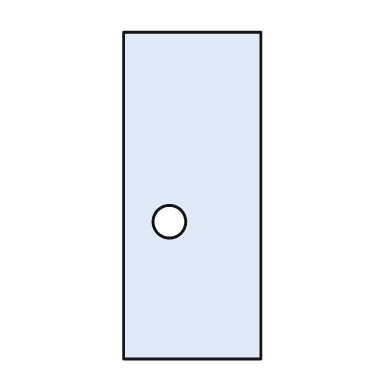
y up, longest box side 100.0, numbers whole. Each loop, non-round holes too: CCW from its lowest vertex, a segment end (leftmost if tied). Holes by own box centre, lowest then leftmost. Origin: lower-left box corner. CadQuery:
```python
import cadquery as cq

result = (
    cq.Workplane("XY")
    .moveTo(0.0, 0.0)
    .lineTo(42.0, 0.0)
    .lineTo(42.0, 100.0)
    .lineTo(0.0, 100.0)
    .close()
    .moveTo(14.0, 42.0)
    .circle(5.0)
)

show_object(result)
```